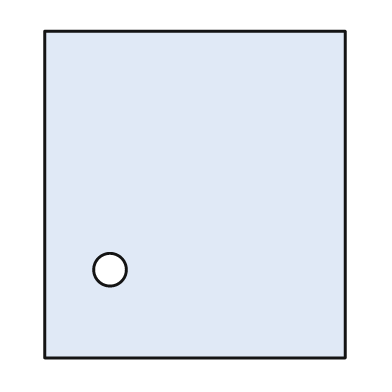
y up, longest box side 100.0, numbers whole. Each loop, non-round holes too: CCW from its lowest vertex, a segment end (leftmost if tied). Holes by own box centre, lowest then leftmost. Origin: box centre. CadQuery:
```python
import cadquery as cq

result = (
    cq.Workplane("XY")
    .moveTo(-46.0, -50.0)
    .lineTo(46.0, -50.0)
    .lineTo(46.0, 50.0)
    .lineTo(-46.0, 50.0)
    .close()
    .moveTo(-26.0, -23.0)
    .circle(5.0)
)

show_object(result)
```